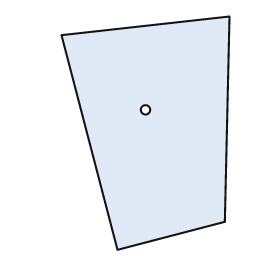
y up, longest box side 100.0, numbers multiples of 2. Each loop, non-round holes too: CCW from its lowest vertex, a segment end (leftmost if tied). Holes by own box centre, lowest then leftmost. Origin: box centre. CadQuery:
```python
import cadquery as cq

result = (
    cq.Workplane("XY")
    .moveTo(-12.0, -50.0)
    .lineTo(34.0, -38.0)
    .lineTo(36.0, 50.0)
    .lineTo(-36.0, 42.0)
    .close()
    .moveTo(0.0, 10.0)
    .circle(2.0)
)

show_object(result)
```